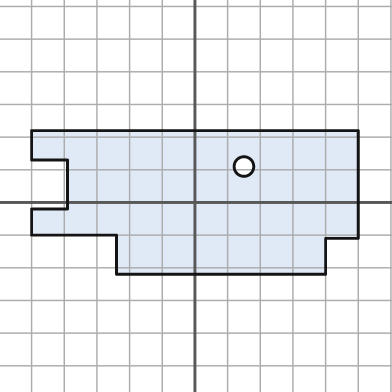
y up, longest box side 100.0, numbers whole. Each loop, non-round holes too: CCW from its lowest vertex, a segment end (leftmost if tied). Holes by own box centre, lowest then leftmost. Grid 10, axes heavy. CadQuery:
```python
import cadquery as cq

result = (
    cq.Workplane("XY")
    .moveTo(-24.0, -22.0)
    .lineTo(40.0, -22.0)
    .lineTo(40.0, -11.0)
    .lineTo(50.0, -11.0)
    .lineTo(50.0, 22.0)
    .lineTo(-50.0, 22.0)
    .lineTo(-50.0, 13.0)
    .lineTo(-39.0, 13.0)
    .lineTo(-39.0, -2.0)
    .lineTo(-50.0, -2.0)
    .lineTo(-50.0, -10.0)
    .lineTo(-24.0, -10.0)
    .close()
    .moveTo(15.0, 11.0)
    .circle(3.0)
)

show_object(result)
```